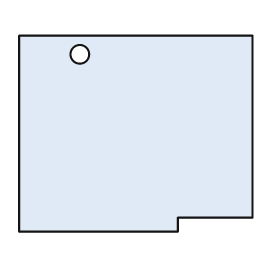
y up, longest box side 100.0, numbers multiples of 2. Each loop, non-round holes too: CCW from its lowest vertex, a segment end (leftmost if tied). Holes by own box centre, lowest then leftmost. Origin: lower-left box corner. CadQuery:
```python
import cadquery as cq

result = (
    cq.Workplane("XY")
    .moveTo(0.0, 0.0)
    .lineTo(68.0, 0.0)
    .lineTo(68.0, 6.0)
    .lineTo(100.0, 6.0)
    .lineTo(100.0, 84.0)
    .lineTo(0.0, 84.0)
    .close()
    .moveTo(26.0, 76.0)
    .circle(4.0)
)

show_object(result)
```